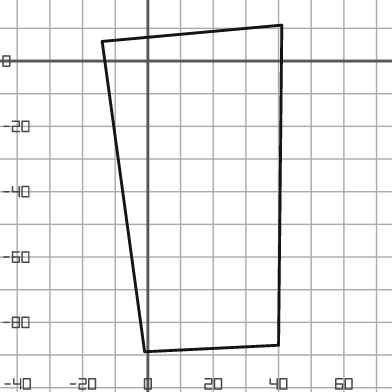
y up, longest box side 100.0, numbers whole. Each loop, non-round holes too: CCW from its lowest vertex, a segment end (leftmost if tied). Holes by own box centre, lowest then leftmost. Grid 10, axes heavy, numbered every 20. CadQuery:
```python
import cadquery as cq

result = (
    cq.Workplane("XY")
    .moveTo(-1.0, -89.0)
    .lineTo(40.0, -87.0)
    .lineTo(41.0, 11.0)
    .lineTo(-14.0, 6.0)
    .close()
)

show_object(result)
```